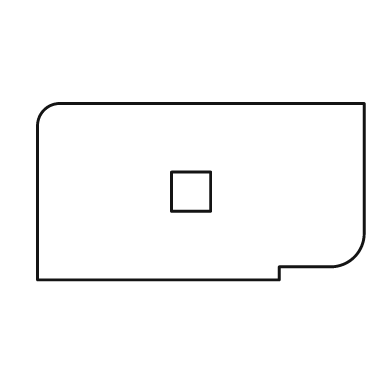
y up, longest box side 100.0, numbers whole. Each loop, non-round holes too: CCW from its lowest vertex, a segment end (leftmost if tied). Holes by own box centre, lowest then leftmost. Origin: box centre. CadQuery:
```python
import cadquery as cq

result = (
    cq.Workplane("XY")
    .moveTo(-50.0, -27.0)
    .lineTo(24.0, -27.0)
    .lineTo(24.0, -23.0)
    .lineTo(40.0, -23.0)
    .threePointArc((47.0, -20.0), (50.0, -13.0))
    .lineTo(50.0, 27.0)
    .lineTo(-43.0, 27.0)
    .threePointArc((-48.0, 25.0), (-50.0, 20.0))
    .close()
    .moveTo(-9.0, -6.0)
    .lineTo(3.0, -6.0)
    .lineTo(3.0, 6.0)
    .lineTo(-9.0, 6.0)
    .close()
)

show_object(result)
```